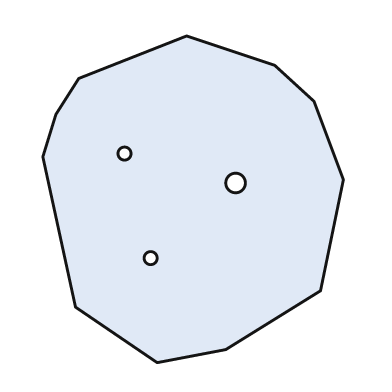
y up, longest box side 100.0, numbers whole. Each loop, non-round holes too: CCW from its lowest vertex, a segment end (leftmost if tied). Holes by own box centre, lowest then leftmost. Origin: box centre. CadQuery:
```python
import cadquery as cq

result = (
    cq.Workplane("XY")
    .moveTo(-11.0, -50.0)
    .lineTo(10.0, -46.0)
    .lineTo(39.0, -28.0)
    .lineTo(46.0, 6.0)
    .lineTo(37.0, 30.0)
    .lineTo(25.0, 41.0)
    .lineTo(-2.0, 50.0)
    .lineTo(-35.0, 37.0)
    .lineTo(-42.0, 26.0)
    .lineTo(-46.0, 13.0)
    .lineTo(-36.0, -33.0)
    .close()
    .moveTo(-13.0, -18.0)
    .circle(2.0)
    .moveTo(13.0, 5.0)
    .circle(3.0)
    .moveTo(-21.0, 14.0)
    .circle(2.0)
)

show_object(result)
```